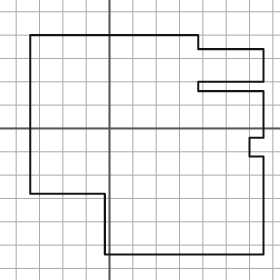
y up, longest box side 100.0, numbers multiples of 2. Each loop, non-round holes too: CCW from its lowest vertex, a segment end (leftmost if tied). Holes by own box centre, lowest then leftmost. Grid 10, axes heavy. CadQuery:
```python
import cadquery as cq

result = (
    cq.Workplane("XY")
    .moveTo(-2.0, -54.0)
    .lineTo(66.0, -54.0)
    .lineTo(66.0, -12.0)
    .lineTo(60.0, -12.0)
    .lineTo(60.0, -4.0)
    .lineTo(66.0, -4.0)
    .lineTo(66.0, 16.0)
    .lineTo(38.0, 16.0)
    .lineTo(38.0, 20.0)
    .lineTo(66.0, 20.0)
    .lineTo(66.0, 34.0)
    .lineTo(38.0, 34.0)
    .lineTo(38.0, 40.0)
    .lineTo(-34.0, 40.0)
    .lineTo(-34.0, -28.0)
    .lineTo(-2.0, -28.0)
    .close()
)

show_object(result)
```